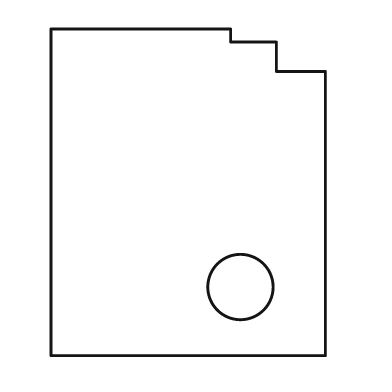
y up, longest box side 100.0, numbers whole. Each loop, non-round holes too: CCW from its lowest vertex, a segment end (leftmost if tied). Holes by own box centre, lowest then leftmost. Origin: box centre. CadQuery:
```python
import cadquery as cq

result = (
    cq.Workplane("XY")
    .moveTo(-42.0, -50.0)
    .lineTo(42.0, -50.0)
    .lineTo(42.0, 37.0)
    .lineTo(27.0, 37.0)
    .lineTo(27.0, 46.0)
    .lineTo(13.0, 46.0)
    .lineTo(13.0, 50.0)
    .lineTo(-42.0, 50.0)
    .close()
    .moveTo(16.0, -29.0)
    .circle(10.0)
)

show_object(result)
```